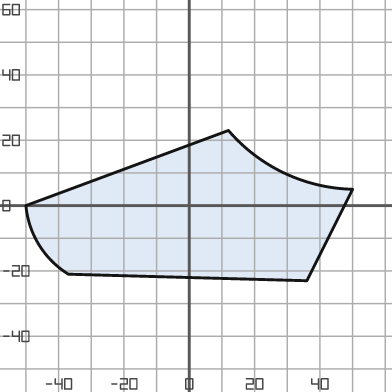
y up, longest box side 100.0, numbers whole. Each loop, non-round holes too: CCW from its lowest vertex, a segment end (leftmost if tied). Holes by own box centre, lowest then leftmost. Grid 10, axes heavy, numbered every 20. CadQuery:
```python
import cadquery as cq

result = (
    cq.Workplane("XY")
    .moveTo(36.0, -23.0)
    .lineTo(50.0, 5.0)
    .threePointArc((29.0, 10.0), (12.0, 23.0))
    .lineTo(-50.0, 0.0)
    .threePointArc((-46.0, -12.0), (-37.0, -21.0))
    .close()
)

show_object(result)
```